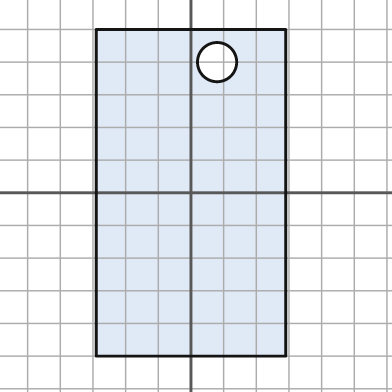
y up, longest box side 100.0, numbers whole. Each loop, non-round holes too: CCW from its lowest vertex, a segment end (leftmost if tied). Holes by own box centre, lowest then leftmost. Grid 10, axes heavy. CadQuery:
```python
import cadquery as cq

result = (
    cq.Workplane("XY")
    .moveTo(-29.0, -50.0)
    .lineTo(29.0, -50.0)
    .lineTo(29.0, 50.0)
    .lineTo(-29.0, 50.0)
    .close()
    .moveTo(8.0, 40.0)
    .circle(6.0)
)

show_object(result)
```